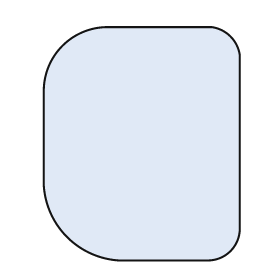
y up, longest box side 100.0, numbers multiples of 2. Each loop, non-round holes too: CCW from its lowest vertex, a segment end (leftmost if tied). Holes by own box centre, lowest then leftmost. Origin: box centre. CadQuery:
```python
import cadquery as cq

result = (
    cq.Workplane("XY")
    .moveTo(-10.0, -50.0)
    .lineTo(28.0, -50.0)
    .threePointArc((38.0, -46.0), (42.0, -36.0))
    .lineTo(42.0, 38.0)
    .threePointArc((38.0, 46.0), (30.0, 50.0))
    .lineTo(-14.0, 50.0)
    .threePointArc((-34.0, 42.0), (-42.0, 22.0))
    .lineTo(-42.0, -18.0)
    .threePointArc((-32.0, -40.0), (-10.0, -50.0))
    .close()
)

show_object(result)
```